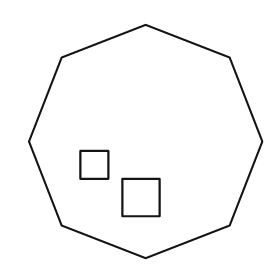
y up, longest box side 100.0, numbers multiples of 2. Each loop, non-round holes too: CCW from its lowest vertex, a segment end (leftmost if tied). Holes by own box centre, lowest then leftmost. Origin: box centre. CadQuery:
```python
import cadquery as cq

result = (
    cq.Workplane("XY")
    .moveTo(0.0, -50.0)
    .lineTo(36.0, -36.0)
    .lineTo(50.0, 0.0)
    .lineTo(36.0, 36.0)
    .lineTo(0.0, 50.0)
    .lineTo(-36.0, 36.0)
    .lineTo(-50.0, 0.0)
    .lineTo(-36.0, -36.0)
    .close()
    .moveTo(-10.0, -32.0)
    .lineTo(6.0, -32.0)
    .lineTo(6.0, -16.0)
    .lineTo(-10.0, -16.0)
    .close()
    .moveTo(-28.0, -16.0)
    .lineTo(-16.0, -16.0)
    .lineTo(-16.0, -4.0)
    .lineTo(-28.0, -4.0)
    .close()
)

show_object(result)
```